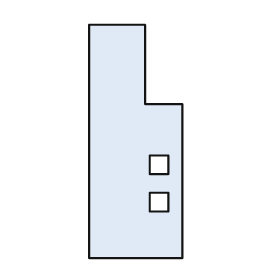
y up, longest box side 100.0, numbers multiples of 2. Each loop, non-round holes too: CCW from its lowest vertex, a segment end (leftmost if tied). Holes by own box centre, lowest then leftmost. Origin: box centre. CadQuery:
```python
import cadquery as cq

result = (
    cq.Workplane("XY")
    .moveTo(-20.0, -50.0)
    .lineTo(20.0, -50.0)
    .lineTo(20.0, 16.0)
    .lineTo(4.0, 16.0)
    .lineTo(4.0, 50.0)
    .lineTo(-20.0, 50.0)
    .close()
    .moveTo(6.0, -30.0)
    .lineTo(14.0, -30.0)
    .lineTo(14.0, -22.0)
    .lineTo(6.0, -22.0)
    .close()
    .moveTo(6.0, -14.0)
    .lineTo(14.0, -14.0)
    .lineTo(14.0, -6.0)
    .lineTo(6.0, -6.0)
    .close()
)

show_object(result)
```